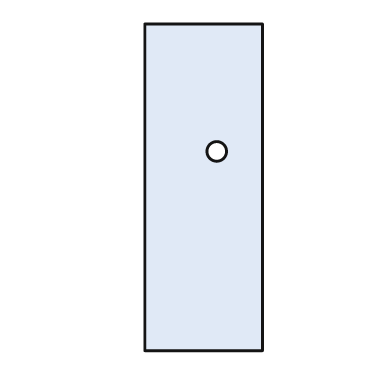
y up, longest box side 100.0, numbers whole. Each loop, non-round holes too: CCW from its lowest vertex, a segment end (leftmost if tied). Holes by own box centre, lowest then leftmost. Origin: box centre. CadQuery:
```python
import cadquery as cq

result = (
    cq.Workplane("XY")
    .moveTo(-18.0, -50.0)
    .lineTo(18.0, -50.0)
    .lineTo(18.0, 50.0)
    .lineTo(-18.0, 50.0)
    .close()
    .moveTo(4.0, 11.0)
    .circle(3.0)
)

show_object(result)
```